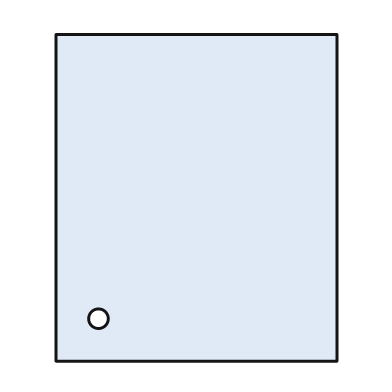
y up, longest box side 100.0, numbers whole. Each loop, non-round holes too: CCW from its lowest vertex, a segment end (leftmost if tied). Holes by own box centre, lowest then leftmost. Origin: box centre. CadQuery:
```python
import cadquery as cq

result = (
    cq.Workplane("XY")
    .moveTo(-43.0, -50.0)
    .lineTo(43.0, -50.0)
    .lineTo(43.0, 50.0)
    .lineTo(-43.0, 50.0)
    .close()
    .moveTo(-30.0, -37.0)
    .circle(3.0)
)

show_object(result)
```